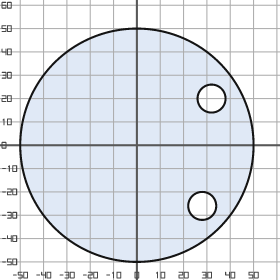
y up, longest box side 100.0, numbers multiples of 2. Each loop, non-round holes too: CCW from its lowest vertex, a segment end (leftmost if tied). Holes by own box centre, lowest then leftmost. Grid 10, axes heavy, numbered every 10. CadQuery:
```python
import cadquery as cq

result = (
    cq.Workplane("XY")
    .moveTo(0.0, 0.0)
    .circle(50.0)
    .moveTo(28.0, -26.0)
    .circle(6.0)
    .moveTo(32.0, 20.0)
    .circle(6.0)
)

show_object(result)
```